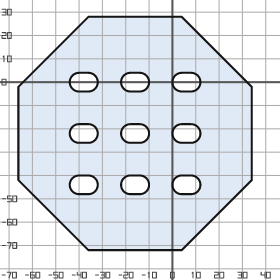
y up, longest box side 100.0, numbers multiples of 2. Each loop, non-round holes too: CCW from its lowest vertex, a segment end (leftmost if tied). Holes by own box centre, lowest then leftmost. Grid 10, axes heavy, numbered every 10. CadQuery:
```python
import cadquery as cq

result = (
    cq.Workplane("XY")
    .moveTo(-36.0, -72.0)
    .lineTo(4.0, -72.0)
    .lineTo(34.0, -42.0)
    .lineTo(34.0, -2.0)
    .lineTo(4.0, 28.0)
    .lineTo(-36.0, 28.0)
    .lineTo(-66.0, -2.0)
    .lineTo(-66.0, -42.0)
    .close()
    .moveTo(-40.0, -48.0)
    .lineTo(-36.0, -48.0)
    .threePointArc((-32.0, -44.0), (-36.0, -40.0))
    .lineTo(-40.0, -40.0)
    .threePointArc((-44.0, -44.0), (-40.0, -48.0))
    .close()
    .moveTo(-18.0, -48.0)
    .lineTo(-14.0, -48.0)
    .threePointArc((-10.0, -44.0), (-14.0, -40.0))
    .lineTo(-18.0, -40.0)
    .threePointArc((-22.0, -44.0), (-18.0, -48.0))
    .close()
    .moveTo(4.0, -48.0)
    .lineTo(8.0, -48.0)
    .threePointArc((12.0, -44.0), (8.0, -40.0))
    .lineTo(4.0, -40.0)
    .threePointArc((0.0, -44.0), (4.0, -48.0))
    .close()
    .moveTo(-40.0, -26.0)
    .lineTo(-36.0, -26.0)
    .threePointArc((-32.0, -22.0), (-36.0, -18.0))
    .lineTo(-40.0, -18.0)
    .threePointArc((-44.0, -22.0), (-40.0, -26.0))
    .close()
    .moveTo(-18.0, -26.0)
    .lineTo(-14.0, -26.0)
    .threePointArc((-10.0, -22.0), (-14.0, -18.0))
    .lineTo(-18.0, -18.0)
    .threePointArc((-22.0, -22.0), (-18.0, -26.0))
    .close()
    .moveTo(4.0, -26.0)
    .lineTo(8.0, -26.0)
    .threePointArc((12.0, -22.0), (8.0, -18.0))
    .lineTo(4.0, -18.0)
    .threePointArc((0.0, -22.0), (4.0, -26.0))
    .close()
    .moveTo(-40.0, -4.0)
    .lineTo(-36.0, -4.0)
    .threePointArc((-32.0, 0.0), (-36.0, 4.0))
    .lineTo(-40.0, 4.0)
    .threePointArc((-44.0, 0.0), (-40.0, -4.0))
    .close()
    .moveTo(-18.0, -4.0)
    .lineTo(-14.0, -4.0)
    .threePointArc((-10.0, 0.0), (-14.0, 4.0))
    .lineTo(-18.0, 4.0)
    .threePointArc((-22.0, 0.0), (-18.0, -4.0))
    .close()
    .moveTo(4.0, -4.0)
    .lineTo(8.0, -4.0)
    .threePointArc((12.0, 0.0), (8.0, 4.0))
    .lineTo(4.0, 4.0)
    .threePointArc((0.0, 0.0), (4.0, -4.0))
    .close()
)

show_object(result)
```